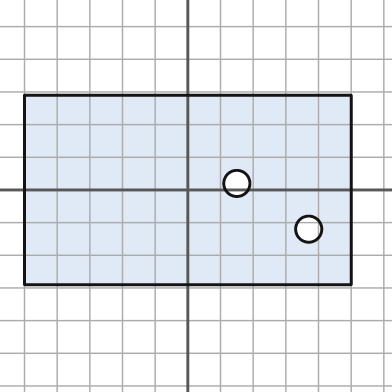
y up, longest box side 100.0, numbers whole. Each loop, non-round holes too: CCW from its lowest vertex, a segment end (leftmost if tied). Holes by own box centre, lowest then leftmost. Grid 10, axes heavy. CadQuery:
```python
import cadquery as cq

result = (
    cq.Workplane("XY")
    .moveTo(-50.0, -29.0)
    .lineTo(50.0, -29.0)
    .lineTo(50.0, 29.0)
    .lineTo(-50.0, 29.0)
    .close()
    .moveTo(37.0, -12.0)
    .circle(4.0)
    .moveTo(15.0, 2.0)
    .circle(4.0)
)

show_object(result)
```